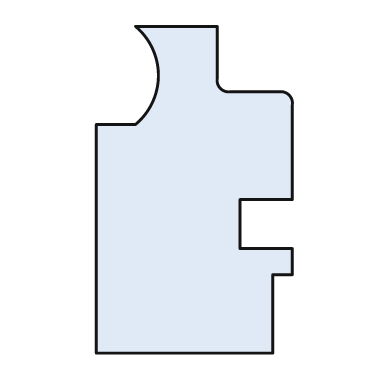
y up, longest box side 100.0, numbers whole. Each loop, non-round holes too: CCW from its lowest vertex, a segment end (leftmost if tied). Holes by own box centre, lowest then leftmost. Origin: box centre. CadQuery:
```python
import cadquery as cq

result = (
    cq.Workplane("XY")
    .moveTo(-30.0, -50.0)
    .lineTo(24.0, -50.0)
    .lineTo(24.0, -26.0)
    .lineTo(30.0, -26.0)
    .lineTo(30.0, -18.0)
    .lineTo(14.0, -18.0)
    .lineTo(14.0, -3.0)
    .lineTo(30.0, -3.0)
    .lineTo(30.0, 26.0)
    .threePointArc((29.0, 29.0), (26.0, 30.0))
    .lineTo(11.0, 30.0)
    .threePointArc((8.0, 31.0), (7.0, 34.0))
    .lineTo(7.0, 50.0)
    .lineTo(-18.0, 50.0)
    .threePointArc((-11.0, 35.0), (-18.0, 20.0))
    .lineTo(-30.0, 20.0)
    .close()
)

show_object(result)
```